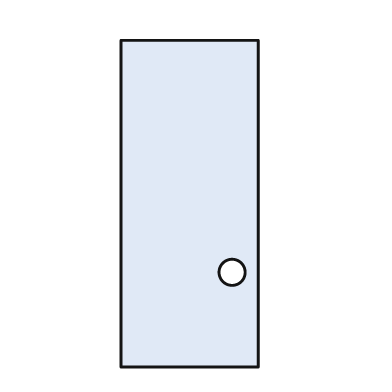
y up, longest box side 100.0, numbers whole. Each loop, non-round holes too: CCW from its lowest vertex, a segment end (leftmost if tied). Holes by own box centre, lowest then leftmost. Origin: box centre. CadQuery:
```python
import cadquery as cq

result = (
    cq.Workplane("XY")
    .moveTo(-21.0, -50.0)
    .lineTo(21.0, -50.0)
    .lineTo(21.0, 50.0)
    .lineTo(-21.0, 50.0)
    .close()
    .moveTo(13.0, -21.0)
    .circle(4.0)
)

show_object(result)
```